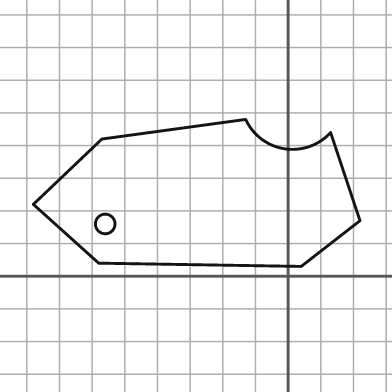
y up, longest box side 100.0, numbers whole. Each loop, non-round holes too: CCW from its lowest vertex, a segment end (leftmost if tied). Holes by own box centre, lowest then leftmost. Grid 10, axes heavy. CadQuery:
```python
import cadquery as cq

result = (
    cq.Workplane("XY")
    .moveTo(4.0, 3.0)
    .lineTo(22.0, 17.0)
    .lineTo(13.0, 44.0)
    .threePointArc((-1.0, 39.0), (-13.0, 48.0))
    .lineTo(-57.0, 42.0)
    .lineTo(-78.0, 22.0)
    .lineTo(-58.0, 4.0)
    .close()
    .moveTo(-56.0, 16.0)
    .circle(3.0)
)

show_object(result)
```